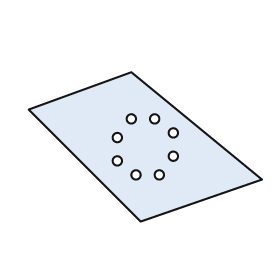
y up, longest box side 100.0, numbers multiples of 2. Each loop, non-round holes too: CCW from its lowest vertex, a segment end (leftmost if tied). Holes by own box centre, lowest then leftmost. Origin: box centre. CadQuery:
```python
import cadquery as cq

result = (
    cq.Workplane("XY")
    .moveTo(-2.0, -32.0)
    .lineTo(50.0, -14.0)
    .lineTo(-6.0, 32.0)
    .lineTo(-50.0, 16.0)
    .close()
    .moveTo(-4.0, -12.0)
    .circle(2.0)
    .moveTo(6.0, -12.0)
    .circle(2.0)
    .moveTo(-12.0, -6.0)
    .circle(2.0)
    .moveTo(12.0, -4.0)
    .circle(2.0)
    .moveTo(-12.0, 4.0)
    .circle(2.0)
    .moveTo(12.0, 6.0)
    .circle(2.0)
    .moveTo(-6.0, 12.0)
    .circle(2.0)
    .moveTo(4.0, 12.0)
    .circle(2.0)
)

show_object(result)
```